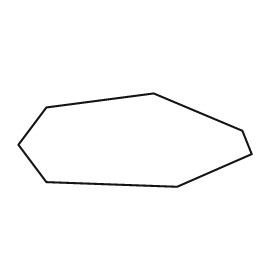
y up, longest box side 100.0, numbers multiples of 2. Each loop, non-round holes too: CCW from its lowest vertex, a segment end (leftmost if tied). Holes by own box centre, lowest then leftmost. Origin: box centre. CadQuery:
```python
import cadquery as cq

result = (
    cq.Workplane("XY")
    .moveTo(18.0, -20.0)
    .lineTo(50.0, -6.0)
    .lineTo(46.0, 4.0)
    .lineTo(8.0, 20.0)
    .lineTo(-38.0, 14.0)
    .lineTo(-50.0, -2.0)
    .lineTo(-38.0, -18.0)
    .close()
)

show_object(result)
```